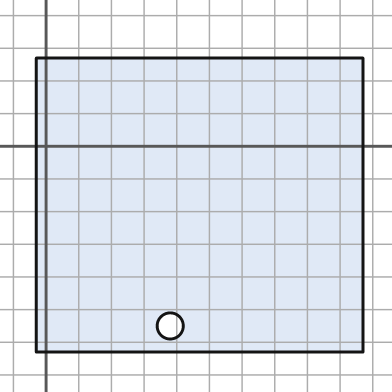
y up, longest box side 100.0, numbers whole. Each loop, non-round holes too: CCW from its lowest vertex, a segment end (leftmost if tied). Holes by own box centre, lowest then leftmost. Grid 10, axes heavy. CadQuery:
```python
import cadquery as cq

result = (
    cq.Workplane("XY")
    .moveTo(-3.0, -63.0)
    .lineTo(97.0, -63.0)
    .lineTo(97.0, 27.0)
    .lineTo(-3.0, 27.0)
    .close()
    .moveTo(38.0, -55.0)
    .circle(4.0)
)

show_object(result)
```